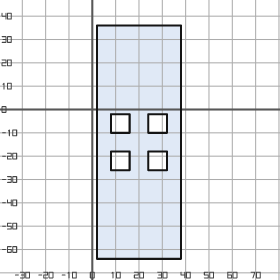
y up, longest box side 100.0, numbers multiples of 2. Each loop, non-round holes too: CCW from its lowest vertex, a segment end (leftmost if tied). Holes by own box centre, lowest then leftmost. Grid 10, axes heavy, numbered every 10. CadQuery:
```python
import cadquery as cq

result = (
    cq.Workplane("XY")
    .moveTo(2.0, -64.0)
    .lineTo(38.0, -64.0)
    .lineTo(38.0, 36.0)
    .lineTo(2.0, 36.0)
    .close()
    .moveTo(8.0, -26.0)
    .lineTo(16.0, -26.0)
    .lineTo(16.0, -18.0)
    .lineTo(8.0, -18.0)
    .close()
    .moveTo(24.0, -26.0)
    .lineTo(32.0, -26.0)
    .lineTo(32.0, -18.0)
    .lineTo(24.0, -18.0)
    .close()
    .moveTo(8.0, -10.0)
    .lineTo(16.0, -10.0)
    .lineTo(16.0, -2.0)
    .lineTo(8.0, -2.0)
    .close()
    .moveTo(24.0, -10.0)
    .lineTo(32.0, -10.0)
    .lineTo(32.0, -2.0)
    .lineTo(24.0, -2.0)
    .close()
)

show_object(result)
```